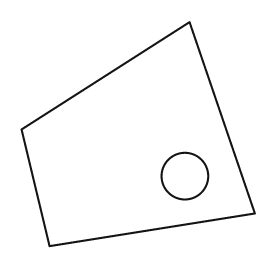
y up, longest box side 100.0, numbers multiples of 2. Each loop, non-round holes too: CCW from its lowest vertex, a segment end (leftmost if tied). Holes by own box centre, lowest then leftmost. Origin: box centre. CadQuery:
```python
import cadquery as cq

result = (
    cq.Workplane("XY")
    .moveTo(-38.0, -48.0)
    .lineTo(50.0, -34.0)
    .lineTo(22.0, 48.0)
    .lineTo(-50.0, 2.0)
    .close()
    .moveTo(20.0, -18.0)
    .circle(10.0)
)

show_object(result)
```